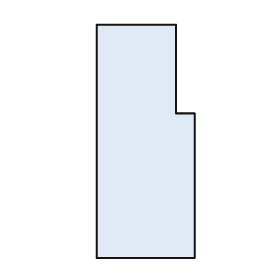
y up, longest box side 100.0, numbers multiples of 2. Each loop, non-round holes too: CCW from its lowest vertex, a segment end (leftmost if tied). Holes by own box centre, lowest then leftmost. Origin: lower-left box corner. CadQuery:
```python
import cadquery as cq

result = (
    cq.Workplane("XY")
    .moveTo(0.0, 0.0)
    .lineTo(42.0, 0.0)
    .lineTo(42.0, 62.0)
    .lineTo(34.0, 62.0)
    .lineTo(34.0, 100.0)
    .lineTo(0.0, 100.0)
    .close()
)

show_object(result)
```